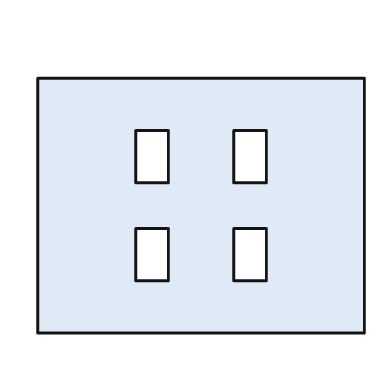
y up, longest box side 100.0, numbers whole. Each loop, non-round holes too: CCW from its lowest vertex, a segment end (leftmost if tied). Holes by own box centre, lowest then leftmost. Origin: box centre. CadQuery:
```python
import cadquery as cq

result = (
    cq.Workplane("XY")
    .moveTo(-50.0, -39.0)
    .lineTo(50.0, -39.0)
    .lineTo(50.0, 39.0)
    .lineTo(-50.0, 39.0)
    .close()
    .moveTo(-20.0, -23.0)
    .lineTo(-10.0, -23.0)
    .lineTo(-10.0, -7.0)
    .lineTo(-20.0, -7.0)
    .close()
    .moveTo(10.0, -23.0)
    .lineTo(20.0, -23.0)
    .lineTo(20.0, -7.0)
    .lineTo(10.0, -7.0)
    .close()
    .moveTo(-20.0, 7.0)
    .lineTo(-10.0, 7.0)
    .lineTo(-10.0, 23.0)
    .lineTo(-20.0, 23.0)
    .close()
    .moveTo(10.0, 7.0)
    .lineTo(20.0, 7.0)
    .lineTo(20.0, 23.0)
    .lineTo(10.0, 23.0)
    .close()
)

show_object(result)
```